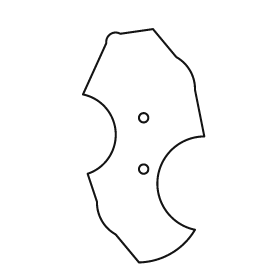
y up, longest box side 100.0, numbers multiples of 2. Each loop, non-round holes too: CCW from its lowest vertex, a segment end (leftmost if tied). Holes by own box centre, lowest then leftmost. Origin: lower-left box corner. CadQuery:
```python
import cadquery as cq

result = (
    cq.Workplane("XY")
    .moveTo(24.0, 0.0)
    .threePointArc((38.0, 4.0), (48.0, 14.0))
    .threePointArc((32.0, 36.0), (52.0, 54.0))
    .lineTo(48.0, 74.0)
    .threePointArc((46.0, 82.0), (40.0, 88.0))
    .lineTo(30.0, 100.0)
    .lineTo(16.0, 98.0)
    .threePointArc((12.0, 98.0), (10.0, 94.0))
    .lineTo(0.0, 72.0)
    .threePointArc((14.0, 56.0), (2.0, 38.0))
    .lineTo(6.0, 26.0)
    .threePointArc((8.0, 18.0), (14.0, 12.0))
    .close()
    .moveTo(26.0, 40.0)
    .circle(2.0)
    .moveTo(26.0, 62.0)
    .circle(2.0)
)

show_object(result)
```